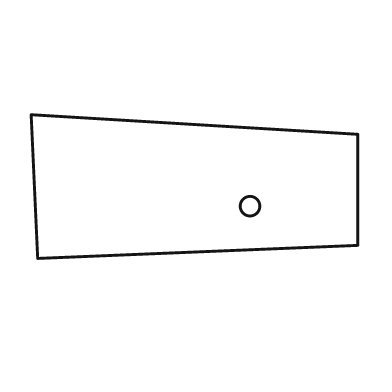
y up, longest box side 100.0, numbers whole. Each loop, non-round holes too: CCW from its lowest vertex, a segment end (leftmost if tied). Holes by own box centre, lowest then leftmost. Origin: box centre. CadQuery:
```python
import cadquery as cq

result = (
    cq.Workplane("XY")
    .moveTo(-48.0, -22.0)
    .lineTo(50.0, -18.0)
    .lineTo(50.0, 16.0)
    .lineTo(-50.0, 22.0)
    .close()
    .moveTo(17.0, -6.0)
    .circle(3.0)
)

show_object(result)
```